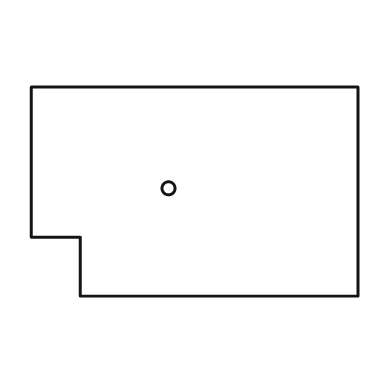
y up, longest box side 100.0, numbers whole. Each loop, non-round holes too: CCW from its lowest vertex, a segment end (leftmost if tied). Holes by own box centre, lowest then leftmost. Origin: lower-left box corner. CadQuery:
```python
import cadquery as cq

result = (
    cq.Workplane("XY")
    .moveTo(15.0, 0.0)
    .lineTo(100.0, 0.0)
    .lineTo(100.0, 64.0)
    .lineTo(0.0, 64.0)
    .lineTo(0.0, 18.0)
    .lineTo(15.0, 18.0)
    .close()
    .moveTo(42.0, 33.0)
    .circle(2.0)
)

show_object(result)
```